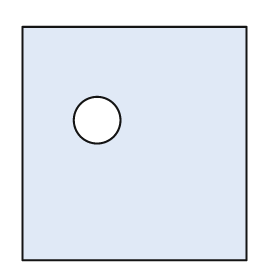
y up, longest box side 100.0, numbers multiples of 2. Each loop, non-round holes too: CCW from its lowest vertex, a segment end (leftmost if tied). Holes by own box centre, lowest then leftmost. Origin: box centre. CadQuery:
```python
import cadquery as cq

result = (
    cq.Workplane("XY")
    .moveTo(-48.0, -50.0)
    .lineTo(48.0, -50.0)
    .lineTo(48.0, 50.0)
    .lineTo(-48.0, 50.0)
    .close()
    .moveTo(-16.0, 10.0)
    .circle(10.0)
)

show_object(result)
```